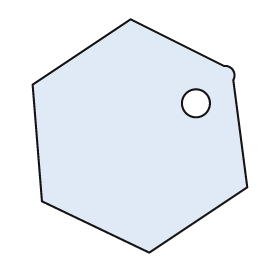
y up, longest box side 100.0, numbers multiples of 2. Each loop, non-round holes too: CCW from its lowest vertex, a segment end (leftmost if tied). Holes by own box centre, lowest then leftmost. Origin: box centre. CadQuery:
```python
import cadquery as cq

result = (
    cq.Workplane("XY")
    .moveTo(4.0, -50.0)
    .lineTo(46.0, -22.0)
    .lineTo(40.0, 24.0)
    .threePointArc((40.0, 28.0), (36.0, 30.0))
    .lineTo(-4.0, 50.0)
    .lineTo(-46.0, 22.0)
    .lineTo(-42.0, -28.0)
    .close()
    .moveTo(24.0, 14.0)
    .circle(6.0)
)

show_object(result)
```